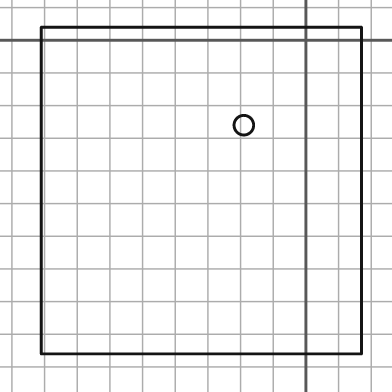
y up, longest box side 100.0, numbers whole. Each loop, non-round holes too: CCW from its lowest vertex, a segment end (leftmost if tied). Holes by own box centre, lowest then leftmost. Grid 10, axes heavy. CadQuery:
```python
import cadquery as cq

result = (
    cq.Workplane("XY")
    .moveTo(-81.0, -96.0)
    .lineTo(17.0, -96.0)
    .lineTo(17.0, 4.0)
    .lineTo(-81.0, 4.0)
    .close()
    .moveTo(-19.0, -26.0)
    .circle(3.0)
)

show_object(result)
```